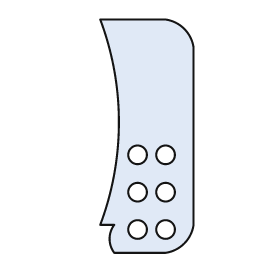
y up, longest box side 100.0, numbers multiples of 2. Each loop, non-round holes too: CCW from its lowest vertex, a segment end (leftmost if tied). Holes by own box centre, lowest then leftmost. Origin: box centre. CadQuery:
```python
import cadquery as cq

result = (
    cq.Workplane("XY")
    .moveTo(-14.0, -50.0)
    .lineTo(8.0, -50.0)
    .threePointArc((16.0, -46.0), (20.0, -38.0))
    .lineTo(20.0, 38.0)
    .threePointArc((16.0, 46.0), (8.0, 50.0))
    .lineTo(-20.0, 50.0)
    .threePointArc((-12.0, 6.0), (-20.0, -38.0))
    .lineTo(-14.0, -38.0)
    .threePointArc((-16.0, -44.0), (-14.0, -50.0))
    .close()
    .moveTo(-4.0, -40.0)
    .circle(4.0)
    .moveTo(8.0, -40.0)
    .circle(4.0)
    .moveTo(-4.0, -24.0)
    .circle(4.0)
    .moveTo(8.0, -24.0)
    .circle(4.0)
    .moveTo(-4.0, -8.0)
    .circle(4.0)
    .moveTo(8.0, -8.0)
    .circle(4.0)
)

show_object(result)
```